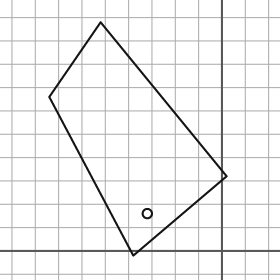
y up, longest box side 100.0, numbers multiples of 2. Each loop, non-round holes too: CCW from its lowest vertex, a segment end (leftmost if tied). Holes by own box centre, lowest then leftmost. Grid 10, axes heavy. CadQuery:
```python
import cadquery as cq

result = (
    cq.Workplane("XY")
    .moveTo(-38.0, -2.0)
    .lineTo(2.0, 32.0)
    .lineTo(-52.0, 98.0)
    .lineTo(-74.0, 66.0)
    .close()
    .moveTo(-32.0, 16.0)
    .circle(2.0)
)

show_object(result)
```